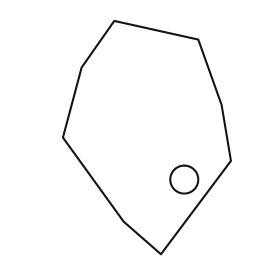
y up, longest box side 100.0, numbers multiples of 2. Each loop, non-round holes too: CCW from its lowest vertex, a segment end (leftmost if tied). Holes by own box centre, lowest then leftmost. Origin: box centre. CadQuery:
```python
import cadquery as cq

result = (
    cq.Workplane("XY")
    .moveTo(6.0, -50.0)
    .lineTo(36.0, -10.0)
    .lineTo(32.0, 14.0)
    .lineTo(22.0, 42.0)
    .lineTo(-14.0, 50.0)
    .lineTo(-28.0, 30.0)
    .lineTo(-36.0, 0.0)
    .lineTo(-10.0, -36.0)
    .close()
    .moveTo(16.0, -18.0)
    .circle(6.0)
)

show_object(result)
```